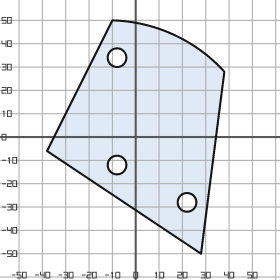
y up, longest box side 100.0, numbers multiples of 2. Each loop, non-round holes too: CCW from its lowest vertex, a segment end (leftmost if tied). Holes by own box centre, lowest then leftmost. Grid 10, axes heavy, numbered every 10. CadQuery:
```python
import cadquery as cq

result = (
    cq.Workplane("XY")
    .moveTo(28.0, -50.0)
    .lineTo(38.0, 28.0)
    .threePointArc((16.0, 44.0), (-10.0, 50.0))
    .lineTo(-38.0, -6.0)
    .close()
    .moveTo(22.0, -28.0)
    .circle(4.0)
    .moveTo(-8.0, -12.0)
    .circle(4.0)
    .moveTo(-8.0, 34.0)
    .circle(4.0)
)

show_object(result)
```